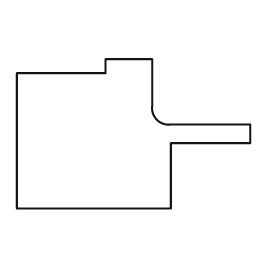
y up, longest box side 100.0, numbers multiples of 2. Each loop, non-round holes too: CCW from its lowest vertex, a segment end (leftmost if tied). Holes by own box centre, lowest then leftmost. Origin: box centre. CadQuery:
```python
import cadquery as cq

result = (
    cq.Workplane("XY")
    .moveTo(-50.0, -32.0)
    .lineTo(16.0, -32.0)
    .lineTo(16.0, -4.0)
    .lineTo(50.0, -4.0)
    .lineTo(50.0, 4.0)
    .lineTo(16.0, 4.0)
    .threePointArc((10.0, 6.0), (8.0, 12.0))
    .lineTo(8.0, 32.0)
    .lineTo(-12.0, 32.0)
    .lineTo(-12.0, 26.0)
    .lineTo(-50.0, 26.0)
    .close()
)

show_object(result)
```